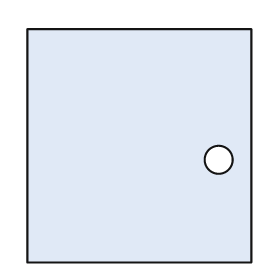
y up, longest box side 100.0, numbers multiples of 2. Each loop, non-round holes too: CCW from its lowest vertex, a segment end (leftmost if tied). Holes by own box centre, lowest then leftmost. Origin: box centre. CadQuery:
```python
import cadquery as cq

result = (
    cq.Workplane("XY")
    .moveTo(-48.0, -50.0)
    .lineTo(48.0, -50.0)
    .lineTo(48.0, 50.0)
    .lineTo(-48.0, 50.0)
    .close()
    .moveTo(34.0, -6.0)
    .circle(6.0)
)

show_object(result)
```